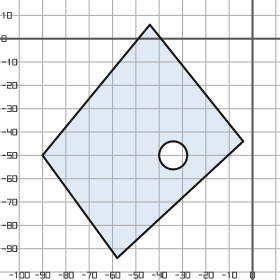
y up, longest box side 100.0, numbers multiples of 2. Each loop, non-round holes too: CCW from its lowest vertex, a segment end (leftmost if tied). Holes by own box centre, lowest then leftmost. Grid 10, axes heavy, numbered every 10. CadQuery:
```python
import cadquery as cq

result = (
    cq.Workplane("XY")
    .moveTo(-58.0, -94.0)
    .lineTo(-4.0, -44.0)
    .lineTo(-44.0, 6.0)
    .lineTo(-90.0, -50.0)
    .close()
    .moveTo(-34.0, -50.0)
    .circle(6.0)
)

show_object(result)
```